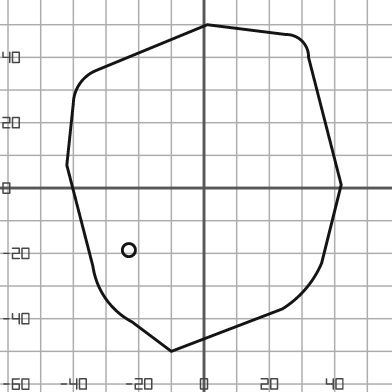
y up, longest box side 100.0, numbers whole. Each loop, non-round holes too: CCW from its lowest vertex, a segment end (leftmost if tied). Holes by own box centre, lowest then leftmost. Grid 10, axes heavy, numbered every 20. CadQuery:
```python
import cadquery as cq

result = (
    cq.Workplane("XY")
    .moveTo(-10.0, -50.0)
    .lineTo(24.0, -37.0)
    .threePointArc((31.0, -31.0), (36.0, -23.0))
    .lineTo(42.0, 1.0)
    .lineTo(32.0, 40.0)
    .threePointArc((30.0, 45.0), (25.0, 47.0))
    .lineTo(1.0, 50.0)
    .lineTo(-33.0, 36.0)
    .threePointArc((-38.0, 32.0), (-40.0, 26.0))
    .lineTo(-42.0, 7.0)
    .lineTo(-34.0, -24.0)
    .threePointArc((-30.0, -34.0), (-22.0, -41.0))
    .close()
    .moveTo(-23.0, -19.0)
    .circle(2.0)
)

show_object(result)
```